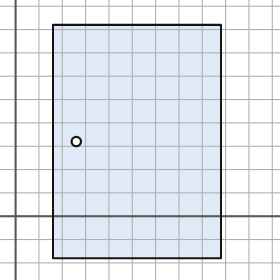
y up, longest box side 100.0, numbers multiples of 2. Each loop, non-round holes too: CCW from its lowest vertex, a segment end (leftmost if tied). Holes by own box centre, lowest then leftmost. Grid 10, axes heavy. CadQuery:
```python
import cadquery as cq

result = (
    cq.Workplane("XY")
    .moveTo(16.0, -18.0)
    .lineTo(88.0, -18.0)
    .lineTo(88.0, 82.0)
    .lineTo(16.0, 82.0)
    .close()
    .moveTo(26.0, 32.0)
    .circle(2.0)
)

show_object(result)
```